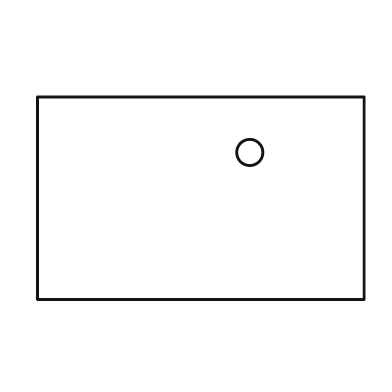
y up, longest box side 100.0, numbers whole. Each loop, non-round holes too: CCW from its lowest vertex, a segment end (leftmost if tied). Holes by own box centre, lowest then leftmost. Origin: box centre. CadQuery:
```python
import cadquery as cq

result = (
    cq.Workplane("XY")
    .moveTo(-50.0, -31.0)
    .lineTo(50.0, -31.0)
    .lineTo(50.0, 31.0)
    .lineTo(-50.0, 31.0)
    .close()
    .moveTo(15.0, 14.0)
    .circle(4.0)
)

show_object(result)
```